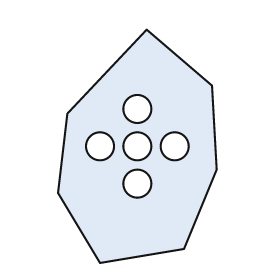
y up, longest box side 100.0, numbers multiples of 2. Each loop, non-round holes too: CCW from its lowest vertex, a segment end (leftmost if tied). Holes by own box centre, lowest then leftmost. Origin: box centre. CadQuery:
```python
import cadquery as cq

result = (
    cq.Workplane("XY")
    .moveTo(-16.0, -50.0)
    .lineTo(20.0, -44.0)
    .lineTo(34.0, -10.0)
    .lineTo(32.0, 26.0)
    .lineTo(4.0, 50.0)
    .lineTo(-30.0, 14.0)
    .lineTo(-34.0, -20.0)
    .close()
    .moveTo(0.0, -16.0)
    .circle(6.0)
    .moveTo(-16.0, 0.0)
    .circle(6.0)
    .moveTo(0.0, 0.0)
    .circle(6.0)
    .moveTo(16.0, 0.0)
    .circle(6.0)
    .moveTo(0.0, 16.0)
    .circle(6.0)
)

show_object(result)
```